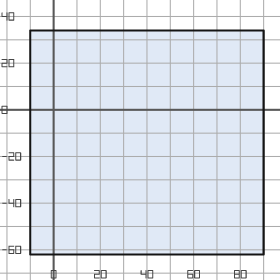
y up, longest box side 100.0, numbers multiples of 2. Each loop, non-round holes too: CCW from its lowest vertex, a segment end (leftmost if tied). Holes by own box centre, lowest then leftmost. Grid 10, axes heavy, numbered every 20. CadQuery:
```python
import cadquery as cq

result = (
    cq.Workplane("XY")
    .moveTo(-10.0, -62.0)
    .lineTo(90.0, -62.0)
    .lineTo(90.0, 34.0)
    .lineTo(-10.0, 34.0)
    .close()
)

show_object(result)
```